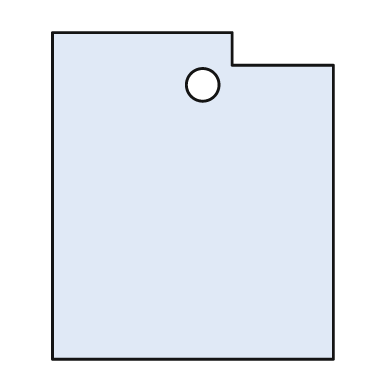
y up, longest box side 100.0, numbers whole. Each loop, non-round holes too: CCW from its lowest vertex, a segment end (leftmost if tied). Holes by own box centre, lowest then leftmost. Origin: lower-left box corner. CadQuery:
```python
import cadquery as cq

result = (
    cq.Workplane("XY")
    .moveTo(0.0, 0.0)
    .lineTo(86.0, 0.0)
    .lineTo(86.0, 90.0)
    .lineTo(55.0, 90.0)
    .lineTo(55.0, 100.0)
    .lineTo(0.0, 100.0)
    .close()
    .moveTo(46.0, 84.0)
    .circle(5.0)
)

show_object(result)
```